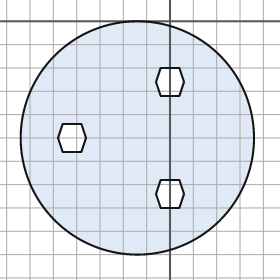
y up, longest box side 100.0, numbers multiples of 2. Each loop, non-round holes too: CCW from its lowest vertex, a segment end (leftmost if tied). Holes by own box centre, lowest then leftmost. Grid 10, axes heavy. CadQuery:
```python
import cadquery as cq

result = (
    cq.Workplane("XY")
    .moveTo(-14.0, -50.0)
    .circle(50.0)
    .moveTo(-4.0, -80.0)
    .lineTo(4.0, -80.0)
    .lineTo(6.0, -74.0)
    .lineTo(4.0, -68.0)
    .lineTo(-4.0, -68.0)
    .lineTo(-6.0, -74.0)
    .close()
    .moveTo(-46.0, -56.0)
    .lineTo(-38.0, -56.0)
    .lineTo(-36.0, -50.0)
    .lineTo(-38.0, -44.0)
    .lineTo(-46.0, -44.0)
    .lineTo(-48.0, -50.0)
    .close()
    .moveTo(-4.0, -32.0)
    .lineTo(4.0, -32.0)
    .lineTo(6.0, -26.0)
    .lineTo(4.0, -20.0)
    .lineTo(-4.0, -20.0)
    .lineTo(-6.0, -26.0)
    .close()
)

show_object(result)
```